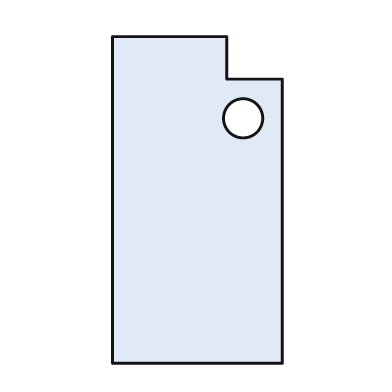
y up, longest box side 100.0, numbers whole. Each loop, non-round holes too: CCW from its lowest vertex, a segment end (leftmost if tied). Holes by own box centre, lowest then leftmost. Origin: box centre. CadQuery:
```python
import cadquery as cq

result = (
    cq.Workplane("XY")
    .moveTo(-26.0, -50.0)
    .lineTo(26.0, -50.0)
    .lineTo(26.0, 37.0)
    .lineTo(9.0, 37.0)
    .lineTo(9.0, 50.0)
    .lineTo(-26.0, 50.0)
    .close()
    .moveTo(14.0, 25.0)
    .circle(6.0)
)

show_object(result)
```